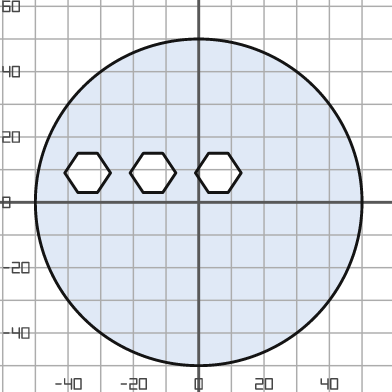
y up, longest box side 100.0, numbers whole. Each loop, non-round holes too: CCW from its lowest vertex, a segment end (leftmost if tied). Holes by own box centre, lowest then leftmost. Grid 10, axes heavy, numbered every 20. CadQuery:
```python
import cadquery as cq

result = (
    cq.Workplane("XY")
    .moveTo(0.0, 0.0)
    .circle(50.0)
    .moveTo(-37.0, 3.0)
    .lineTo(-31.0, 3.0)
    .lineTo(-27.0, 9.0)
    .lineTo(-31.0, 15.0)
    .lineTo(-37.0, 15.0)
    .lineTo(-41.0, 9.0)
    .close()
    .moveTo(-17.0, 3.0)
    .lineTo(-11.0, 3.0)
    .lineTo(-7.0, 9.0)
    .lineTo(-11.0, 15.0)
    .lineTo(-17.0, 15.0)
    .lineTo(-21.0, 9.0)
    .close()
    .moveTo(3.0, 3.0)
    .lineTo(9.0, 3.0)
    .lineTo(13.0, 9.0)
    .lineTo(9.0, 15.0)
    .lineTo(3.0, 15.0)
    .lineTo(-1.0, 9.0)
    .close()
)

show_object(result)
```